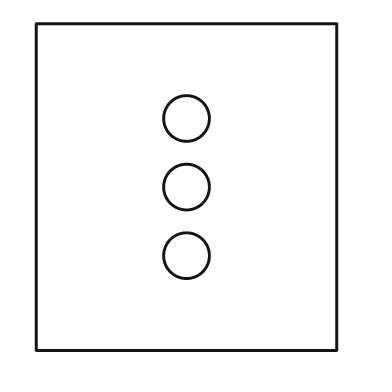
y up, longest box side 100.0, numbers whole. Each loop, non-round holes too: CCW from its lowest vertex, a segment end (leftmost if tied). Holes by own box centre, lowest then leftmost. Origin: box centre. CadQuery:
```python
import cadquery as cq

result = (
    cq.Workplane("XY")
    .moveTo(-46.0, -50.0)
    .lineTo(46.0, -50.0)
    .lineTo(46.0, 50.0)
    .lineTo(-46.0, 50.0)
    .close()
    .moveTo(0.0, -21.0)
    .circle(7.0)
    .moveTo(0.0, 0.0)
    .circle(7.0)
    .moveTo(0.0, 21.0)
    .circle(7.0)
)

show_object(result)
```